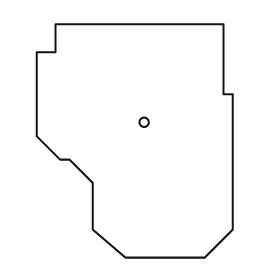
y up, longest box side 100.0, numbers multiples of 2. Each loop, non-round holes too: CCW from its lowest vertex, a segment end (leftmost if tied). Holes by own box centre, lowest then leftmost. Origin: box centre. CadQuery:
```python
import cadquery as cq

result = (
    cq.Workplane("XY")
    .moveTo(-4.0, -50.0)
    .lineTo(30.0, -50.0)
    .lineTo(42.0, -38.0)
    .lineTo(42.0, 20.0)
    .lineTo(38.0, 20.0)
    .lineTo(38.0, 50.0)
    .lineTo(-34.0, 50.0)
    .lineTo(-34.0, 38.0)
    .lineTo(-42.0, 38.0)
    .lineTo(-42.0, 2.0)
    .lineTo(-32.0, -8.0)
    .lineTo(-28.0, -8.0)
    .lineTo(-18.0, -18.0)
    .lineTo(-18.0, -38.0)
    .close()
    .moveTo(4.0, 8.0)
    .circle(2.0)
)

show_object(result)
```